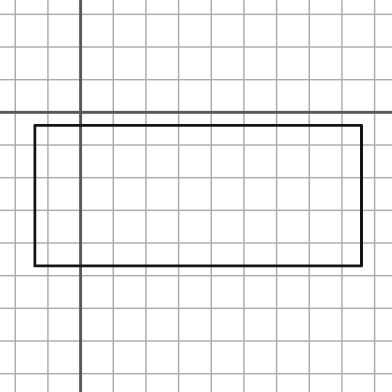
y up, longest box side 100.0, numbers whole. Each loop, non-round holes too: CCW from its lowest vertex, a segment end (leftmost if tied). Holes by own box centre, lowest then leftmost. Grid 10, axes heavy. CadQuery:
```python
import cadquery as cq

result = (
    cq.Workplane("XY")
    .moveTo(-14.0, -47.0)
    .lineTo(86.0, -47.0)
    .lineTo(86.0, -4.0)
    .lineTo(-14.0, -4.0)
    .close()
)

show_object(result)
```